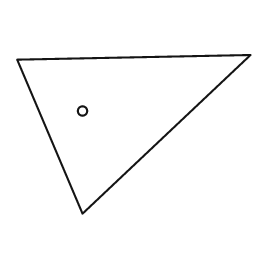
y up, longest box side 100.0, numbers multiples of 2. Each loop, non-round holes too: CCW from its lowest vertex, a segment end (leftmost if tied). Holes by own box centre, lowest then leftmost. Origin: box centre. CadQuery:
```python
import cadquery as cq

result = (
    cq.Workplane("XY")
    .moveTo(-22.0, -34.0)
    .lineTo(50.0, 34.0)
    .lineTo(-50.0, 32.0)
    .close()
    .moveTo(-22.0, 10.0)
    .circle(2.0)
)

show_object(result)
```